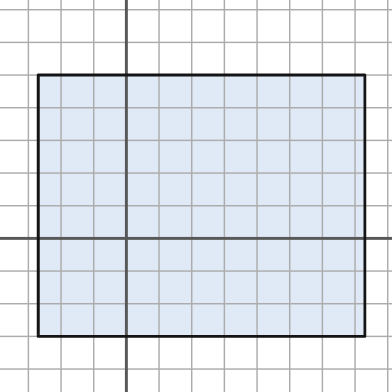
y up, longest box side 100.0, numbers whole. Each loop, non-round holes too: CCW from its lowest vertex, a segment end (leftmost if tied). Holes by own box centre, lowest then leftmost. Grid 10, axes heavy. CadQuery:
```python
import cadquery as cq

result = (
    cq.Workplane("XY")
    .moveTo(-27.0, -30.0)
    .lineTo(73.0, -30.0)
    .lineTo(73.0, 50.0)
    .lineTo(-27.0, 50.0)
    .close()
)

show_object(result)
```